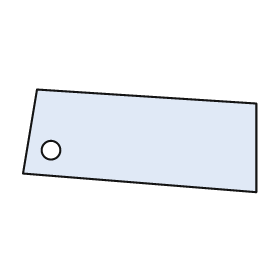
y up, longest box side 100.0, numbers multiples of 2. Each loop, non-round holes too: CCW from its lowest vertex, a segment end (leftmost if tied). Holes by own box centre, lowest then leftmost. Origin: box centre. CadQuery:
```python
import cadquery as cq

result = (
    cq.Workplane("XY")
    .moveTo(50.0, -22.0)
    .lineTo(50.0, 16.0)
    .lineTo(-44.0, 22.0)
    .lineTo(-50.0, -14.0)
    .close()
    .moveTo(-38.0, -4.0)
    .circle(4.0)
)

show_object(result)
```